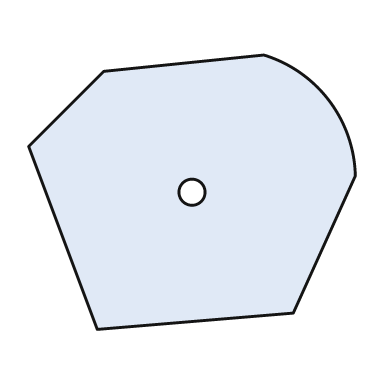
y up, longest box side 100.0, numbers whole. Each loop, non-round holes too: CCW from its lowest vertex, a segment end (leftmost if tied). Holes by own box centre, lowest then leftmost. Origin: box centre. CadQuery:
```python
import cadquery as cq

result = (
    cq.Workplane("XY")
    .moveTo(-29.0, -42.0)
    .lineTo(31.0, -37.0)
    .lineTo(50.0, 5.0)
    .threePointArc((42.0, 28.0), (22.0, 42.0))
    .lineTo(-27.0, 37.0)
    .lineTo(-50.0, 14.0)
    .close()
    .moveTo(0.0, 0.0)
    .circle(4.0)
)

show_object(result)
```